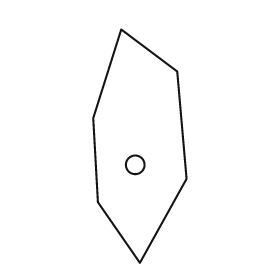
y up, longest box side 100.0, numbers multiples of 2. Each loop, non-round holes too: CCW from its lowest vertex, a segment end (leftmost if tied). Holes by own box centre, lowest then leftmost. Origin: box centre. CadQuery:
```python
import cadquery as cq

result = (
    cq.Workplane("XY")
    .moveTo(0.0, -50.0)
    .lineTo(20.0, -14.0)
    .lineTo(16.0, 32.0)
    .lineTo(-8.0, 50.0)
    .lineTo(-20.0, 12.0)
    .lineTo(-18.0, -24.0)
    .close()
    .moveTo(-2.0, -8.0)
    .circle(4.0)
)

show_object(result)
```